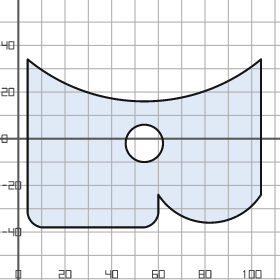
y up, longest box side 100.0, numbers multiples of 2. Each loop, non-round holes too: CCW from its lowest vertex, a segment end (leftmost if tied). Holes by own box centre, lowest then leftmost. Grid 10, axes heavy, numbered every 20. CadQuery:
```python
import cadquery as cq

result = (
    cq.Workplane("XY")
    .moveTo(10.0, -38.0)
    .lineTo(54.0, -38.0)
    .threePointArc((58.0, -36.0), (60.0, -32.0))
    .lineTo(60.0, -24.0)
    .threePointArc((82.0, -36.0), (104.0, -24.0))
    .lineTo(104.0, 34.0)
    .threePointArc((54.0, 16.0), (4.0, 34.0))
    .lineTo(4.0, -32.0)
    .threePointArc((6.0, -36.0), (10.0, -38.0))
    .close()
    .moveTo(54.0, -2.0)
    .circle(8.0)
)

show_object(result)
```